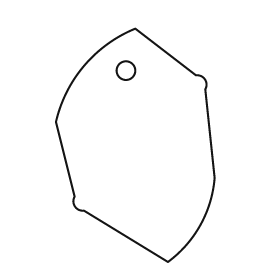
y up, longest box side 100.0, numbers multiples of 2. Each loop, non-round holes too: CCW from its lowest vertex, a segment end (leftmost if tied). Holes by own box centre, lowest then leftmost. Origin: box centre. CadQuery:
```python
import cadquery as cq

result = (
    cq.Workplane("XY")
    .moveTo(14.0, -50.0)
    .threePointArc((28.0, -34.0), (34.0, -14.0))
    .lineTo(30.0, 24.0)
    .threePointArc((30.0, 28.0), (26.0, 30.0))
    .lineTo(0.0, 50.0)
    .threePointArc((-22.0, 34.0), (-34.0, 10.0))
    .lineTo(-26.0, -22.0)
    .threePointArc((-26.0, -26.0), (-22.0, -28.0))
    .close()
    .moveTo(-4.0, 32.0)
    .circle(4.0)
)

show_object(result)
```